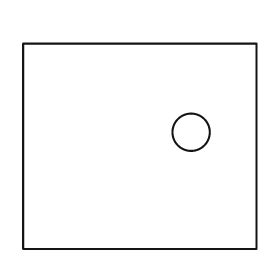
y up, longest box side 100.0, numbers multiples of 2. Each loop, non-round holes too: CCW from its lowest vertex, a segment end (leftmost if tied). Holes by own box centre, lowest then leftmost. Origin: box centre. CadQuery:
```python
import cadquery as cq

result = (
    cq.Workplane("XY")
    .moveTo(-50.0, -44.0)
    .lineTo(50.0, -44.0)
    .lineTo(50.0, 44.0)
    .lineTo(-50.0, 44.0)
    .close()
    .moveTo(22.0, 6.0)
    .circle(8.0)
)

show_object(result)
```